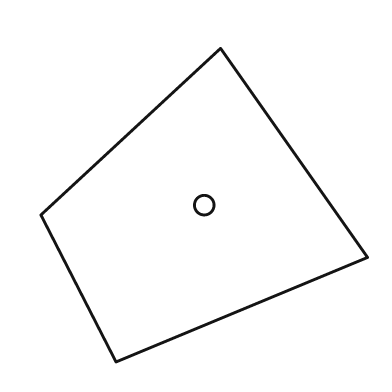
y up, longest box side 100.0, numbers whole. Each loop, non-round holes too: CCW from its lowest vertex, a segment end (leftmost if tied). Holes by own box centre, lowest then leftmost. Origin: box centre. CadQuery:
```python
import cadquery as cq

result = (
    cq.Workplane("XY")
    .moveTo(-27.0, -48.0)
    .lineTo(50.0, -16.0)
    .lineTo(5.0, 48.0)
    .lineTo(-50.0, -3.0)
    .close()
    .moveTo(0.0, 0.0)
    .circle(3.0)
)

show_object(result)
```